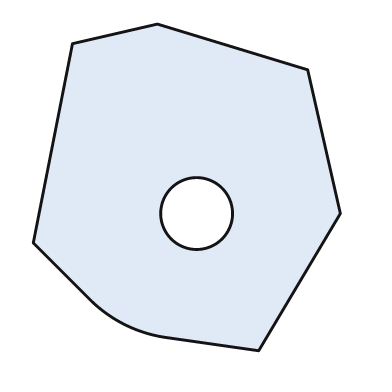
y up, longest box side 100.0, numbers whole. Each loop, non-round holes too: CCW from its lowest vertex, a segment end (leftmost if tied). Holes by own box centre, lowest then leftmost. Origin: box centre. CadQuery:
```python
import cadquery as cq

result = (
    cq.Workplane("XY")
    .moveTo(22.0, -50.0)
    .lineTo(47.0, -8.0)
    .lineTo(37.0, 36.0)
    .lineTo(-9.0, 50.0)
    .lineTo(-35.0, 44.0)
    .lineTo(-47.0, -17.0)
    .lineTo(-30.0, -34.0)
    .threePointArc((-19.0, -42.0), (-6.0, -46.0))
    .close()
    .moveTo(3.0, -8.0)
    .circle(11.0)
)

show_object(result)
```